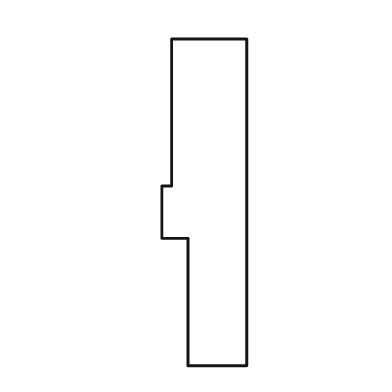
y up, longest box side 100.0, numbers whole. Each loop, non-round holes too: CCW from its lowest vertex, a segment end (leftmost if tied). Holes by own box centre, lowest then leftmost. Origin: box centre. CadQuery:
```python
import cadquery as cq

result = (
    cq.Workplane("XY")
    .moveTo(-5.0, -50.0)
    .lineTo(13.0, -50.0)
    .lineTo(13.0, 50.0)
    .lineTo(-10.0, 50.0)
    .lineTo(-10.0, 5.0)
    .lineTo(-13.0, 5.0)
    .lineTo(-13.0, -11.0)
    .lineTo(-5.0, -11.0)
    .close()
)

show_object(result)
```